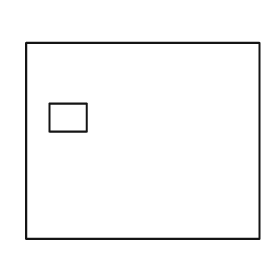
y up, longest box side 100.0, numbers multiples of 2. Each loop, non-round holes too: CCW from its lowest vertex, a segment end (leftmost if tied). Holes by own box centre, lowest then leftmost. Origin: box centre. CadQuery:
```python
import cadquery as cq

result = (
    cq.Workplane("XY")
    .moveTo(-50.0, -42.0)
    .lineTo(50.0, -42.0)
    .lineTo(50.0, 42.0)
    .lineTo(-50.0, 42.0)
    .close()
    .moveTo(-40.0, 4.0)
    .lineTo(-24.0, 4.0)
    .lineTo(-24.0, 16.0)
    .lineTo(-40.0, 16.0)
    .close()
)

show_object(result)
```